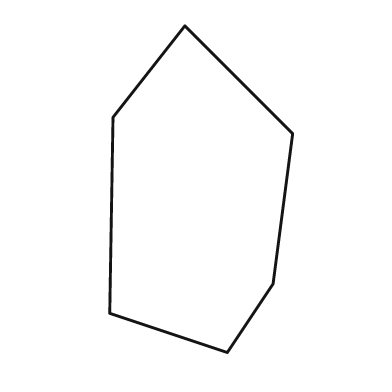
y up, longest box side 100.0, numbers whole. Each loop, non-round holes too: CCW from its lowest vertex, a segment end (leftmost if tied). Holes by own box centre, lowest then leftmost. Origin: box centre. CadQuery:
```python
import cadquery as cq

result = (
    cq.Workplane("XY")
    .moveTo(8.0, -50.0)
    .lineTo(22.0, -29.0)
    .lineTo(28.0, 17.0)
    .lineTo(-5.0, 50.0)
    .lineTo(-27.0, 22.0)
    .lineTo(-28.0, -38.0)
    .close()
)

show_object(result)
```